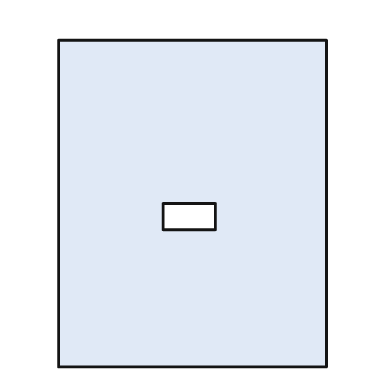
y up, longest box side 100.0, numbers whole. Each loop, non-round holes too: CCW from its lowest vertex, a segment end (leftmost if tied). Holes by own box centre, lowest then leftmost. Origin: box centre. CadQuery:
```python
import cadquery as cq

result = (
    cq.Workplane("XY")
    .moveTo(-41.0, -50.0)
    .lineTo(41.0, -50.0)
    .lineTo(41.0, 50.0)
    .lineTo(-41.0, 50.0)
    .close()
    .moveTo(-9.0, -8.0)
    .lineTo(7.0, -8.0)
    .lineTo(7.0, 0.0)
    .lineTo(-9.0, 0.0)
    .close()
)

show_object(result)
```